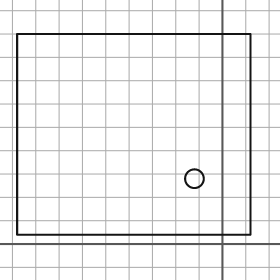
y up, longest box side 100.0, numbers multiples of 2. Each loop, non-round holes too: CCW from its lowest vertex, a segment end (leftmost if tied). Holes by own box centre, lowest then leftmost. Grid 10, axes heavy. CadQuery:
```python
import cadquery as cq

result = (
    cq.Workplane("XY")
    .moveTo(-88.0, 4.0)
    .lineTo(12.0, 4.0)
    .lineTo(12.0, 90.0)
    .lineTo(-88.0, 90.0)
    .close()
    .moveTo(-12.0, 28.0)
    .circle(4.0)
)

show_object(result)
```